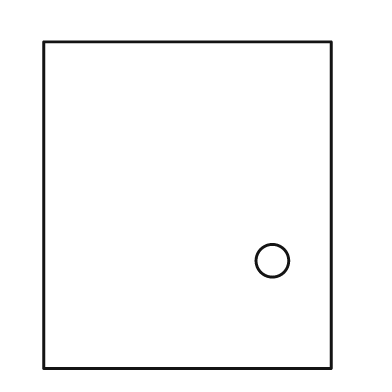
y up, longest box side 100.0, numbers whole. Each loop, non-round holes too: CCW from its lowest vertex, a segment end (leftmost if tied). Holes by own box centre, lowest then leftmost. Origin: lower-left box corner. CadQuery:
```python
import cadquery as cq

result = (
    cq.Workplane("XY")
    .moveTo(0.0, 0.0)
    .lineTo(88.0, 0.0)
    .lineTo(88.0, 100.0)
    .lineTo(0.0, 100.0)
    .close()
    .moveTo(70.0, 33.0)
    .circle(5.0)
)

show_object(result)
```